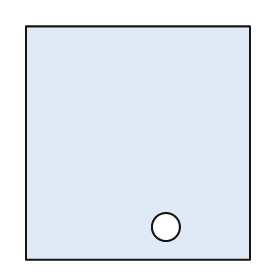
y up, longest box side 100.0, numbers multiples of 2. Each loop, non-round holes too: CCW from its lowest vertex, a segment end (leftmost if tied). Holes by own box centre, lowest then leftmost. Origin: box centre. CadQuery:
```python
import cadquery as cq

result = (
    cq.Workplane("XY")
    .moveTo(-48.0, -50.0)
    .lineTo(48.0, -50.0)
    .lineTo(48.0, 50.0)
    .lineTo(-48.0, 50.0)
    .close()
    .moveTo(12.0, -36.0)
    .circle(6.0)
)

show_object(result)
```